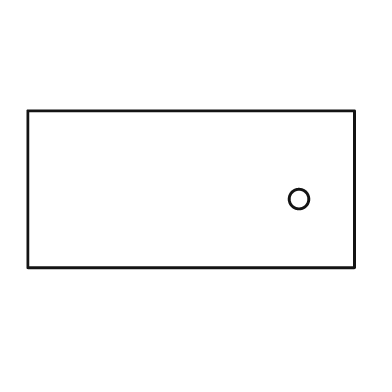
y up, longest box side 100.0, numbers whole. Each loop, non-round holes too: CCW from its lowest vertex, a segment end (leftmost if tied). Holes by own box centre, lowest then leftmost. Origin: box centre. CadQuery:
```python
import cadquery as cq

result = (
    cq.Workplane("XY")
    .moveTo(-50.0, -24.0)
    .lineTo(50.0, -24.0)
    .lineTo(50.0, 24.0)
    .lineTo(-50.0, 24.0)
    .close()
    .moveTo(33.0, -3.0)
    .circle(3.0)
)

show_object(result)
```